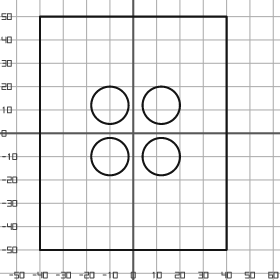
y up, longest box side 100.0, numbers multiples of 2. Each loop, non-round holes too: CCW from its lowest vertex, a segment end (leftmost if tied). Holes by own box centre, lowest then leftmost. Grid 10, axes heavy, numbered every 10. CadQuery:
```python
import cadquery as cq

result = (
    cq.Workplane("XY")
    .moveTo(-40.0, -50.0)
    .lineTo(40.0, -50.0)
    .lineTo(40.0, 50.0)
    .lineTo(-40.0, 50.0)
    .close()
    .moveTo(-10.0, -10.0)
    .circle(8.0)
    .moveTo(12.0, -10.0)
    .circle(8.0)
    .moveTo(-10.0, 12.0)
    .circle(8.0)
    .moveTo(12.0, 12.0)
    .circle(8.0)
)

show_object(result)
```